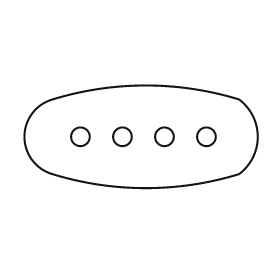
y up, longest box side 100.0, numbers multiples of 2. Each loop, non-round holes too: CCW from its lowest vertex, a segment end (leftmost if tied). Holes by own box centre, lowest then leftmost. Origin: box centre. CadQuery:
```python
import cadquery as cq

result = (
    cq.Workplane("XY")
    .moveTo(-38.0, -16.0)
    .threePointArc((2.0, -22.0), (42.0, -16.0))
    .threePointArc((50.0, 0.0), (42.0, 16.0))
    .threePointArc((2.0, 22.0), (-38.0, 16.0))
    .threePointArc((-50.0, 0.0), (-38.0, -16.0))
    .close()
    .moveTo(-26.0, 0.0)
    .circle(4.0)
    .moveTo(-8.0, 0.0)
    .circle(4.0)
    .moveTo(10.0, 0.0)
    .circle(4.0)
    .moveTo(28.0, 0.0)
    .circle(4.0)
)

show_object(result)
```